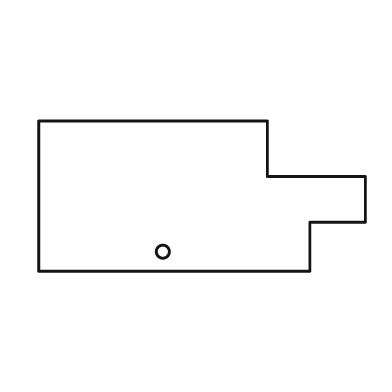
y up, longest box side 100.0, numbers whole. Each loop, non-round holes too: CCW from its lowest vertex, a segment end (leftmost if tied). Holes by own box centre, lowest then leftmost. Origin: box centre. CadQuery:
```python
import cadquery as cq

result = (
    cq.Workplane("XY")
    .moveTo(-50.0, -23.0)
    .lineTo(33.0, -23.0)
    .lineTo(33.0, -8.0)
    .lineTo(50.0, -8.0)
    .lineTo(50.0, 6.0)
    .lineTo(20.0, 6.0)
    .lineTo(20.0, 23.0)
    .lineTo(-50.0, 23.0)
    .close()
    .moveTo(-12.0, -17.0)
    .circle(2.0)
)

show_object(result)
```